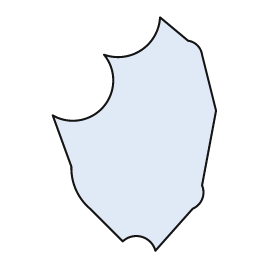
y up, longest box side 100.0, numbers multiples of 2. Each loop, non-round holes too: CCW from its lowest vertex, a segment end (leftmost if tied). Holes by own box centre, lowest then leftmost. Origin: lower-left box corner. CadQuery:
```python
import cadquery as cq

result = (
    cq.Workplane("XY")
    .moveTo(44.0, 0.0)
    .lineTo(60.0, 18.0)
    .threePointArc((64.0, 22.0), (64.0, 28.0))
    .lineTo(70.0, 60.0)
    .lineTo(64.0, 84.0)
    .threePointArc((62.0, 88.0), (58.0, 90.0))
    .lineTo(46.0, 100.0)
    .threePointArc((38.0, 86.0), (22.0, 84.0))
    .threePointArc((22.0, 62.0), (0.0, 58.0))
    .lineTo(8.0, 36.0)
    .threePointArc((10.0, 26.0), (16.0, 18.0))
    .lineTo(30.0, 4.0)
    .threePointArc((38.0, 6.0), (44.0, 0.0))
    .close()
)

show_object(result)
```